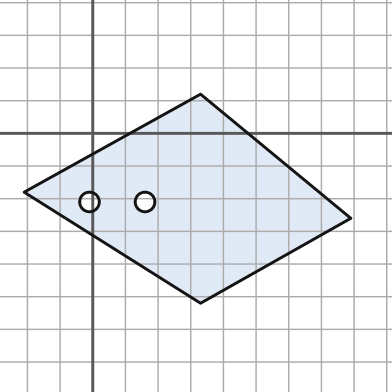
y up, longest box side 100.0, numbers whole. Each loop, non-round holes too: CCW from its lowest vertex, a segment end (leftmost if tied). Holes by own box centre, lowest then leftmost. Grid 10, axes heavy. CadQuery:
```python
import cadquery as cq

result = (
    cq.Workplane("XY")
    .moveTo(33.0, -52.0)
    .lineTo(79.0, -26.0)
    .lineTo(33.0, 12.0)
    .lineTo(-21.0, -18.0)
    .close()
    .moveTo(-1.0, -21.0)
    .circle(3.0)
    .moveTo(16.0, -21.0)
    .circle(3.0)
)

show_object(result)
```